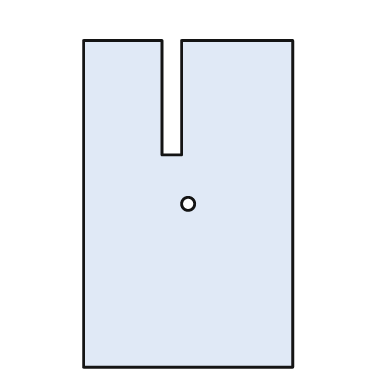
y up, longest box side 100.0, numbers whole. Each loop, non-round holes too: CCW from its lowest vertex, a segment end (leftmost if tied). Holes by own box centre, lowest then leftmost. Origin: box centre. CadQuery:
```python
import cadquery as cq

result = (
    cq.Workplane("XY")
    .moveTo(-32.0, -50.0)
    .lineTo(32.0, -50.0)
    .lineTo(32.0, 50.0)
    .lineTo(-2.0, 50.0)
    .lineTo(-2.0, 15.0)
    .lineTo(-8.0, 15.0)
    .lineTo(-8.0, 50.0)
    .lineTo(-32.0, 50.0)
    .close()
    .moveTo(0.0, 0.0)
    .circle(2.0)
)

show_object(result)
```